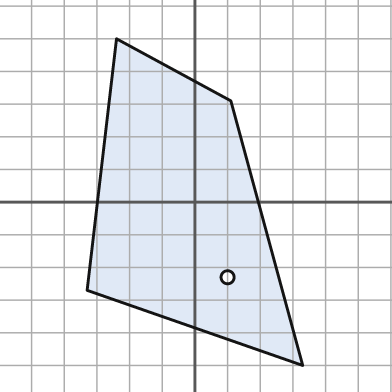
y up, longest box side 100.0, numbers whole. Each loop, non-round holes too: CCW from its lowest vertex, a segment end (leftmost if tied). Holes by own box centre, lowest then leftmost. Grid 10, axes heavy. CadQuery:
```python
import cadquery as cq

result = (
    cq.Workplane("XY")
    .moveTo(33.0, -50.0)
    .lineTo(11.0, 31.0)
    .lineTo(-24.0, 50.0)
    .lineTo(-33.0, -27.0)
    .close()
    .moveTo(10.0, -23.0)
    .circle(2.0)
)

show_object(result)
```